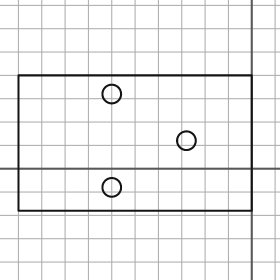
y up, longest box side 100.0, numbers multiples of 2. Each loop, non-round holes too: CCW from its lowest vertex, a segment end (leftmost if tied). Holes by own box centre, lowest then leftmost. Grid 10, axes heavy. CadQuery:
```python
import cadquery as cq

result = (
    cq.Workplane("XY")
    .moveTo(-100.0, -18.0)
    .lineTo(0.0, -18.0)
    .lineTo(0.0, 40.0)
    .lineTo(-100.0, 40.0)
    .close()
    .moveTo(-60.0, -8.0)
    .circle(4.0)
    .moveTo(-28.0, 12.0)
    .circle(4.0)
    .moveTo(-60.0, 32.0)
    .circle(4.0)
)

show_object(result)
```